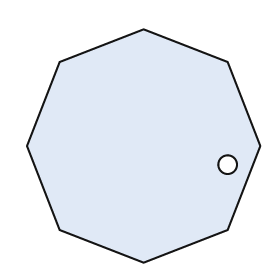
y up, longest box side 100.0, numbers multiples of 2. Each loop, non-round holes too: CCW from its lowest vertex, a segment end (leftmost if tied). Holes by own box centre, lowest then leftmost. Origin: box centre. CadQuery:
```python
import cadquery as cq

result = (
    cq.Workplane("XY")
    .moveTo(0.0, -50.0)
    .lineTo(36.0, -36.0)
    .lineTo(50.0, 0.0)
    .lineTo(36.0, 36.0)
    .lineTo(0.0, 50.0)
    .lineTo(-36.0, 36.0)
    .lineTo(-50.0, 0.0)
    .lineTo(-36.0, -36.0)
    .close()
    .moveTo(36.0, -8.0)
    .circle(4.0)
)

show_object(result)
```